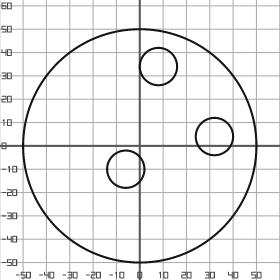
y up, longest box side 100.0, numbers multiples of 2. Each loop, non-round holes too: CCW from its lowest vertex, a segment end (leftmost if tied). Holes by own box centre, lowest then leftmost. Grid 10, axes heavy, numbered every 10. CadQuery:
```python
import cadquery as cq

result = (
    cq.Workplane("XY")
    .moveTo(0.0, 0.0)
    .circle(50.0)
    .moveTo(-6.0, -10.0)
    .circle(8.0)
    .moveTo(32.0, 4.0)
    .circle(8.0)
    .moveTo(8.0, 34.0)
    .circle(8.0)
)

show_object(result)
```